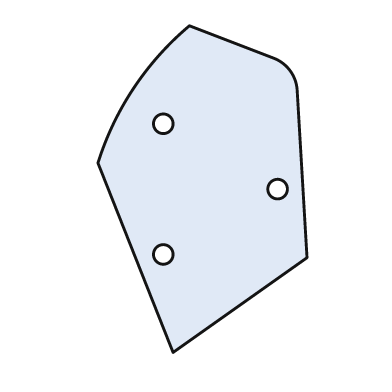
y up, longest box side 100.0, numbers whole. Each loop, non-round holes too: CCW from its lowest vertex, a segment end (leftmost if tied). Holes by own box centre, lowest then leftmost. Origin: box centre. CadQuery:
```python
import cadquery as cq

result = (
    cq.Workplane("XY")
    .moveTo(-9.0, -50.0)
    .lineTo(32.0, -21.0)
    .lineTo(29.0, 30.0)
    .threePointArc((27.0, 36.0), (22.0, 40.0))
    .lineTo(-4.0, 50.0)
    .threePointArc((-21.0, 31.0), (-32.0, 8.0))
    .close()
    .moveTo(-12.0, -20.0)
    .circle(3.0)
    .moveTo(23.0, 0.0)
    .circle(3.0)
    .moveTo(-12.0, 20.0)
    .circle(3.0)
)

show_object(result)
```